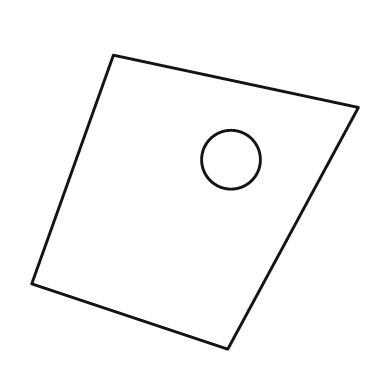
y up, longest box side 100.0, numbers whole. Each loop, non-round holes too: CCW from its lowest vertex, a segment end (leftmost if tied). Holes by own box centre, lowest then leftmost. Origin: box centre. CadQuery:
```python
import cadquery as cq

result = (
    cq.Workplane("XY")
    .moveTo(10.0, -45.0)
    .lineTo(50.0, 29.0)
    .lineTo(-25.0, 45.0)
    .lineTo(-50.0, -25.0)
    .close()
    .moveTo(11.0, 13.0)
    .circle(9.0)
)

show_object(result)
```